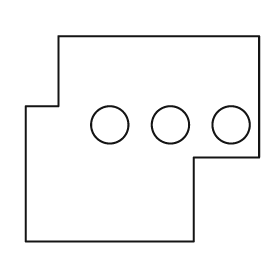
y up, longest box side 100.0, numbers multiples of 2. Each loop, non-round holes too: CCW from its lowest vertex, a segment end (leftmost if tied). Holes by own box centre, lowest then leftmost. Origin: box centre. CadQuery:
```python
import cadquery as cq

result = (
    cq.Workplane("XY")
    .moveTo(-50.0, -44.0)
    .lineTo(22.0, -44.0)
    .lineTo(22.0, -8.0)
    .lineTo(50.0, -8.0)
    .lineTo(50.0, 44.0)
    .lineTo(-36.0, 44.0)
    .lineTo(-36.0, 14.0)
    .lineTo(-50.0, 14.0)
    .close()
    .moveTo(-14.0, 6.0)
    .circle(8.0)
    .moveTo(12.0, 6.0)
    .circle(8.0)
    .moveTo(38.0, 6.0)
    .circle(8.0)
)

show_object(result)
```